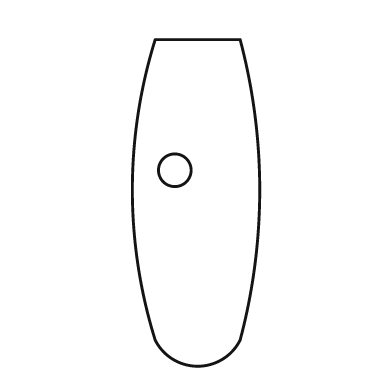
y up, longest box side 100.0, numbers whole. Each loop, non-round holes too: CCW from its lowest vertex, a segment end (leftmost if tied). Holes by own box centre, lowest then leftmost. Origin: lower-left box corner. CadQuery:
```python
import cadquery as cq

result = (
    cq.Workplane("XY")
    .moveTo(7.0, 8.0)
    .threePointArc((20.0, 0.0), (33.0, 8.0))
    .threePointArc((39.0, 54.0), (33.0, 100.0))
    .lineTo(7.0, 100.0)
    .threePointArc((0.0, 54.0), (7.0, 8.0))
    .close()
    .moveTo(13.0, 60.0)
    .circle(5.0)
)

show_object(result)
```